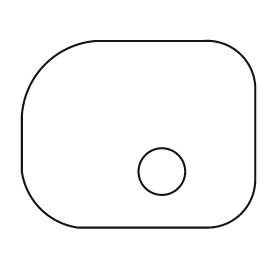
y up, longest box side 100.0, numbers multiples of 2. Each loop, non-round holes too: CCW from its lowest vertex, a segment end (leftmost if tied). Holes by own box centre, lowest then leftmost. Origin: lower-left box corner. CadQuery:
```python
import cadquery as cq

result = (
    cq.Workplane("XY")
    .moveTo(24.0, 0.0)
    .lineTo(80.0, 0.0)
    .threePointArc((94.0, 6.0), (100.0, 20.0))
    .lineTo(100.0, 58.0)
    .threePointArc((94.0, 74.0), (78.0, 80.0))
    .lineTo(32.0, 80.0)
    .threePointArc((10.0, 70.0), (0.0, 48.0))
    .lineTo(0.0, 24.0)
    .threePointArc((8.0, 8.0), (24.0, 0.0))
    .close()
    .moveTo(60.0, 24.0)
    .circle(10.0)
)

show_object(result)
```